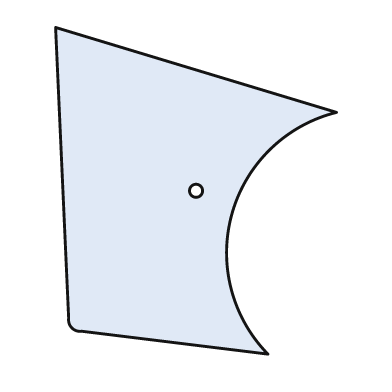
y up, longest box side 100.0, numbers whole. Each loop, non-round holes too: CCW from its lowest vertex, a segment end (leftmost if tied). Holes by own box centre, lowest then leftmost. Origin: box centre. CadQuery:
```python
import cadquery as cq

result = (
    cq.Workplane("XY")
    .moveTo(22.0, -50.0)
    .threePointArc((11.0, -7.0), (43.0, 24.0))
    .lineTo(-43.0, 50.0)
    .lineTo(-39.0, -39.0)
    .threePointArc((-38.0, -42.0), (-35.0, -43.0))
    .close()
    .moveTo(0.0, 0.0)
    .circle(2.0)
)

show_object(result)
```